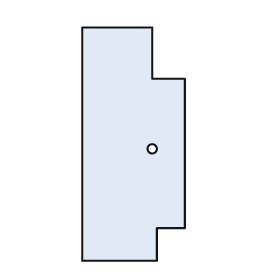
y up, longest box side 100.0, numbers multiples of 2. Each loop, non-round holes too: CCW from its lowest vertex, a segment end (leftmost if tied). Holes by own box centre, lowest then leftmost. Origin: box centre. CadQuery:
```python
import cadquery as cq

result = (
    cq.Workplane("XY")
    .moveTo(-22.0, -50.0)
    .lineTo(10.0, -50.0)
    .lineTo(10.0, -36.0)
    .lineTo(22.0, -36.0)
    .lineTo(22.0, 28.0)
    .lineTo(8.0, 28.0)
    .lineTo(8.0, 50.0)
    .lineTo(-22.0, 50.0)
    .close()
    .moveTo(8.0, -2.0)
    .circle(2.0)
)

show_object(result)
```